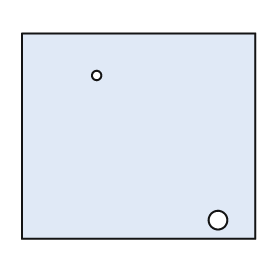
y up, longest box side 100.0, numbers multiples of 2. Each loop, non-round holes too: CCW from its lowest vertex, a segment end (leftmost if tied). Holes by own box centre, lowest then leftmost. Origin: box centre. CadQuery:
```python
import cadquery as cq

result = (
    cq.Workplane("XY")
    .moveTo(-50.0, -44.0)
    .lineTo(50.0, -44.0)
    .lineTo(50.0, 44.0)
    .lineTo(-50.0, 44.0)
    .close()
    .moveTo(34.0, -36.0)
    .circle(4.0)
    .moveTo(-18.0, 26.0)
    .circle(2.0)
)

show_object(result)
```